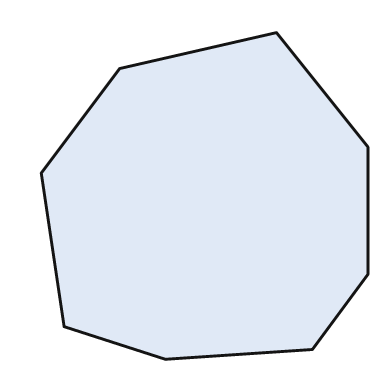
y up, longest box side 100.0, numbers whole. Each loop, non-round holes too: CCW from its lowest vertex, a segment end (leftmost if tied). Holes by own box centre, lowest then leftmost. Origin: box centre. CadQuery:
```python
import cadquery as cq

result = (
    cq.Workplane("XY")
    .moveTo(-12.0, -50.0)
    .lineTo(33.0, -47.0)
    .lineTo(50.0, -24.0)
    .lineTo(50.0, 15.0)
    .lineTo(22.0, 50.0)
    .lineTo(-26.0, 39.0)
    .lineTo(-50.0, 7.0)
    .lineTo(-43.0, -40.0)
    .close()
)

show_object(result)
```